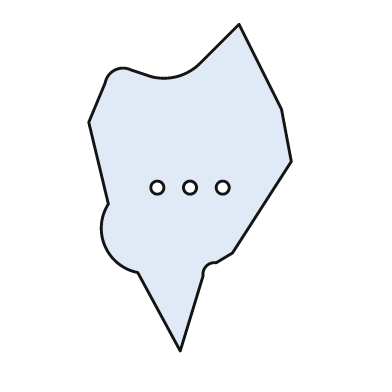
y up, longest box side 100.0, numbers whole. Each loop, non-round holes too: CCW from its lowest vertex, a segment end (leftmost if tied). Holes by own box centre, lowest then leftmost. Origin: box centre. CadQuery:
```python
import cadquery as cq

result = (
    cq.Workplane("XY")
    .moveTo(-3.0, -50.0)
    .lineTo(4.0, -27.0)
    .threePointArc((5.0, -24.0), (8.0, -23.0))
    .lineTo(13.0, -20.0)
    .lineTo(31.0, 8.0)
    .lineTo(28.0, 24.0)
    .lineTo(15.0, 50.0)
    .lineTo(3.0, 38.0)
    .threePointArc((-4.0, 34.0), (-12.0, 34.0))
    .lineTo(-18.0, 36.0)
    .threePointArc((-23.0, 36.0), (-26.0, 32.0))
    .lineTo(-31.0, 20.0)
    .lineTo(-25.0, -5.0)
    .threePointArc((-26.0, -18.0), (-16.0, -26.0))
    .close()
    .moveTo(-10.0, 0.0)
    .circle(2.0)
    .moveTo(0.0, 0.0)
    .circle(2.0)
    .moveTo(10.0, 0.0)
    .circle(2.0)
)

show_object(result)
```